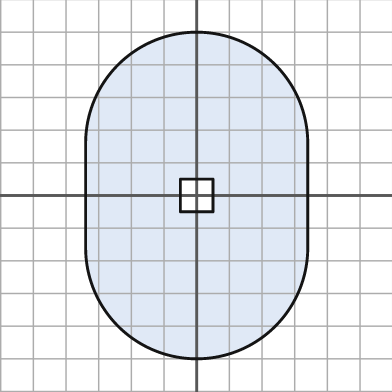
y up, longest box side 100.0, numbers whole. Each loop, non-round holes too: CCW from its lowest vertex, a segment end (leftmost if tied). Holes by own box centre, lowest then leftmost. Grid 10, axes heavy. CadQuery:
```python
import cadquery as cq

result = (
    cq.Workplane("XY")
    .moveTo(-34.0, -16.0)
    .threePointArc((0.0, -50.0), (34.0, -16.0))
    .lineTo(34.0, 16.0)
    .threePointArc((0.0, 50.0), (-34.0, 16.0))
    .close()
    .moveTo(-5.0, -5.0)
    .lineTo(5.0, -5.0)
    .lineTo(5.0, 5.0)
    .lineTo(-5.0, 5.0)
    .close()
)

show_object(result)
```